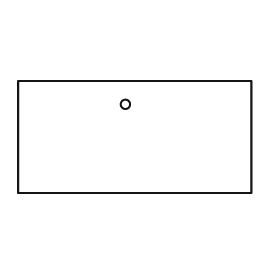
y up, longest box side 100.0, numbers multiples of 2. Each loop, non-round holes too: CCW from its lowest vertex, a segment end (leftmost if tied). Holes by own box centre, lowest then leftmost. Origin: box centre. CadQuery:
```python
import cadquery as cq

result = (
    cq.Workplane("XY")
    .moveTo(-50.0, -24.0)
    .lineTo(50.0, -24.0)
    .lineTo(50.0, 24.0)
    .lineTo(-50.0, 24.0)
    .close()
    .moveTo(-4.0, 14.0)
    .circle(2.0)
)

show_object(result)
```